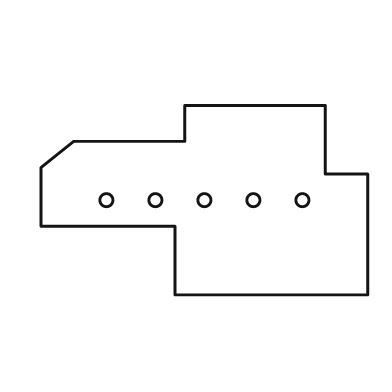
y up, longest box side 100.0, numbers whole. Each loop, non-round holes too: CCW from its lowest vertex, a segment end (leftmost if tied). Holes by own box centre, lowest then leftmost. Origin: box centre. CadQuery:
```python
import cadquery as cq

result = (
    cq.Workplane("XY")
    .moveTo(-9.0, -29.0)
    .lineTo(50.0, -29.0)
    .lineTo(50.0, 8.0)
    .lineTo(37.0, 8.0)
    .lineTo(37.0, 29.0)
    .lineTo(-6.0, 29.0)
    .lineTo(-6.0, 18.0)
    .lineTo(-40.0, 18.0)
    .lineTo(-50.0, 10.0)
    .lineTo(-50.0, -8.0)
    .lineTo(-9.0, -8.0)
    .close()
    .moveTo(-30.0, 0.0)
    .circle(2.0)
    .moveTo(-15.0, 0.0)
    .circle(2.0)
    .moveTo(0.0, 0.0)
    .circle(2.0)
    .moveTo(15.0, 0.0)
    .circle(2.0)
    .moveTo(30.0, 0.0)
    .circle(2.0)
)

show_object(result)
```